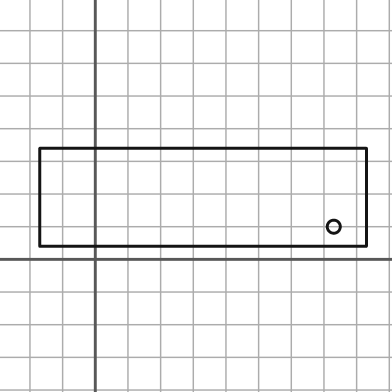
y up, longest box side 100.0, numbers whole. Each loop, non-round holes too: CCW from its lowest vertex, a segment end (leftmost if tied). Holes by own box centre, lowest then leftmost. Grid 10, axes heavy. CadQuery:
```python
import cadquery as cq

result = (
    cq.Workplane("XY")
    .moveTo(-17.0, 4.0)
    .lineTo(83.0, 4.0)
    .lineTo(83.0, 34.0)
    .lineTo(-17.0, 34.0)
    .close()
    .moveTo(73.0, 10.0)
    .circle(2.0)
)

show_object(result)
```